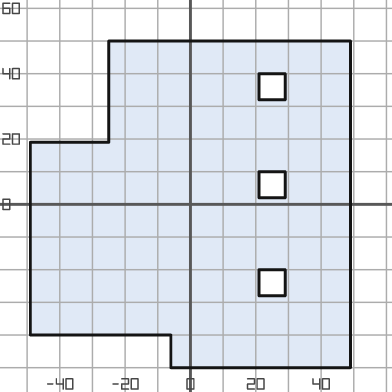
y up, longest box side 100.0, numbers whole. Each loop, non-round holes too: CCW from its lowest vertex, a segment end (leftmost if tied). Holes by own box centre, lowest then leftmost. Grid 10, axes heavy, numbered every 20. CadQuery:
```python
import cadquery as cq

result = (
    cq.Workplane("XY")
    .moveTo(-6.0, -50.0)
    .lineTo(49.0, -50.0)
    .lineTo(49.0, 50.0)
    .lineTo(-25.0, 50.0)
    .lineTo(-25.0, 19.0)
    .lineTo(-49.0, 19.0)
    .lineTo(-49.0, -40.0)
    .lineTo(-6.0, -40.0)
    .close()
    .moveTo(21.0, -28.0)
    .lineTo(29.0, -28.0)
    .lineTo(29.0, -20.0)
    .lineTo(21.0, -20.0)
    .close()
    .moveTo(21.0, 2.0)
    .lineTo(29.0, 2.0)
    .lineTo(29.0, 10.0)
    .lineTo(21.0, 10.0)
    .close()
    .moveTo(21.0, 32.0)
    .lineTo(29.0, 32.0)
    .lineTo(29.0, 40.0)
    .lineTo(21.0, 40.0)
    .close()
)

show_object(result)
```